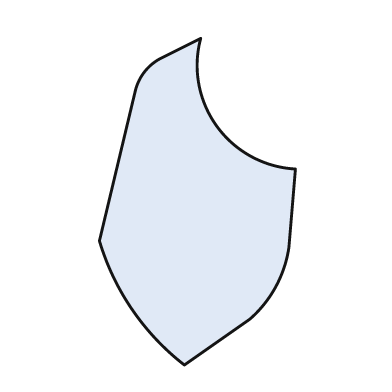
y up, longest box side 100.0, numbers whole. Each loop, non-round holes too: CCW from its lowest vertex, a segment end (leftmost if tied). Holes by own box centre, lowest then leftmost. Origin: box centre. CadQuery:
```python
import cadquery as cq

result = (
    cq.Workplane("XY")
    .moveTo(-4.0, -50.0)
    .lineTo(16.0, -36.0)
    .threePointArc((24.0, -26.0), (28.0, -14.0))
    .lineTo(30.0, 10.0)
    .threePointArc((6.0, 23.0), (1.0, 50.0))
    .lineTo(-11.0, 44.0)
    .threePointArc((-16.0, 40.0), (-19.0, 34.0))
    .lineTo(-30.0, -12.0)
    .threePointArc((-20.0, -33.0), (-4.0, -50.0))
    .close()
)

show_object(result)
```